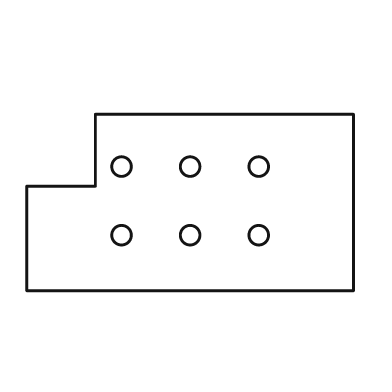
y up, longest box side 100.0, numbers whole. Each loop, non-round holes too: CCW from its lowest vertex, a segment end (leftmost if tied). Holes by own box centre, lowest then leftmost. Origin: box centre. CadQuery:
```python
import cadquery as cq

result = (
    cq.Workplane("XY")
    .moveTo(-50.0, -27.0)
    .lineTo(50.0, -27.0)
    .lineTo(50.0, 27.0)
    .lineTo(-29.0, 27.0)
    .lineTo(-29.0, 5.0)
    .lineTo(-50.0, 5.0)
    .close()
    .moveTo(-21.0, -10.0)
    .circle(3.0)
    .moveTo(0.0, -10.0)
    .circle(3.0)
    .moveTo(21.0, -10.0)
    .circle(3.0)
    .moveTo(-21.0, 11.0)
    .circle(3.0)
    .moveTo(0.0, 11.0)
    .circle(3.0)
    .moveTo(21.0, 11.0)
    .circle(3.0)
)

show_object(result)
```